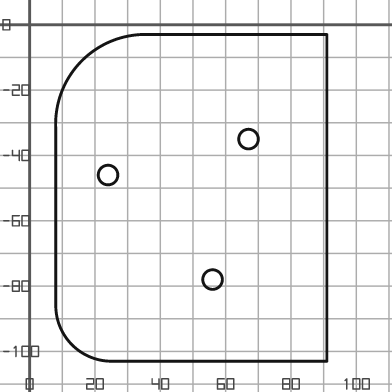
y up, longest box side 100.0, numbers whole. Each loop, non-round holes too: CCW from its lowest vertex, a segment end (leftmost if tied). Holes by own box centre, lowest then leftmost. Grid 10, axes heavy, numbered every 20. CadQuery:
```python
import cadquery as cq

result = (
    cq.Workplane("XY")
    .moveTo(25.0, -103.0)
    .lineTo(91.0, -103.0)
    .lineTo(91.0, -3.0)
    .lineTo(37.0, -3.0)
    .threePointArc((16.0, -11.0), (8.0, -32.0))
    .lineTo(8.0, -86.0)
    .threePointArc((13.0, -98.0), (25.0, -103.0))
    .close()
    .moveTo(56.0, -78.0)
    .circle(3.0)
    .moveTo(24.0, -46.0)
    .circle(3.0)
    .moveTo(67.0, -35.0)
    .circle(3.0)
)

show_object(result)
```